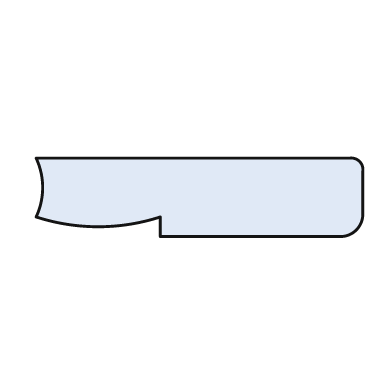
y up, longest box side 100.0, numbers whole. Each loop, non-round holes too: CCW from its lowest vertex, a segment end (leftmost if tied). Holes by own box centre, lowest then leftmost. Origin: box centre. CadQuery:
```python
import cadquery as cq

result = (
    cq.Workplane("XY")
    .moveTo(-12.0, -12.0)
    .lineTo(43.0, -12.0)
    .threePointArc((48.0, -10.0), (50.0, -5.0))
    .lineTo(50.0, 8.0)
    .threePointArc((49.0, 11.0), (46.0, 12.0))
    .lineTo(-50.0, 12.0)
    .threePointArc((-48.0, 3.0), (-50.0, -6.0))
    .threePointArc((-31.0, -9.0), (-12.0, -6.0))
    .close()
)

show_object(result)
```